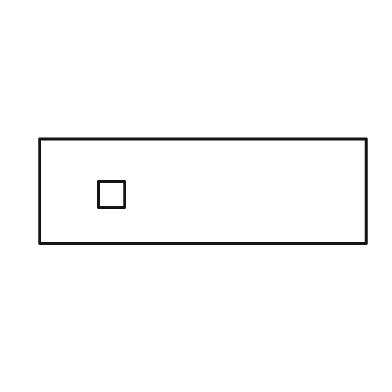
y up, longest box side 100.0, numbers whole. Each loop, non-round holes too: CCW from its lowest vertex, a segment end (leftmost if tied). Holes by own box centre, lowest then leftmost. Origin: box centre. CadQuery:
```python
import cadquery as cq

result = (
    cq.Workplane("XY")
    .moveTo(-50.0, -16.0)
    .lineTo(50.0, -16.0)
    .lineTo(50.0, 16.0)
    .lineTo(-50.0, 16.0)
    .close()
    .moveTo(-32.0, -5.0)
    .lineTo(-24.0, -5.0)
    .lineTo(-24.0, 3.0)
    .lineTo(-32.0, 3.0)
    .close()
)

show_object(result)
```